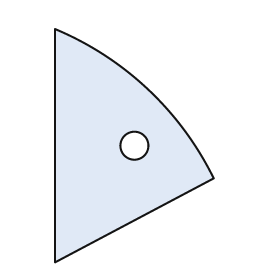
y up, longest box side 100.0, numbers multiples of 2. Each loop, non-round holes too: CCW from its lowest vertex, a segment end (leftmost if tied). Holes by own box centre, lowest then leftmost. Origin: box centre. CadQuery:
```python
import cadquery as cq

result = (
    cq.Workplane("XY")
    .moveTo(-34.0, -50.0)
    .lineTo(34.0, -14.0)
    .threePointArc((6.0, 24.0), (-34.0, 50.0))
    .close()
    .moveTo(0.0, 0.0)
    .circle(6.0)
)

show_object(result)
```